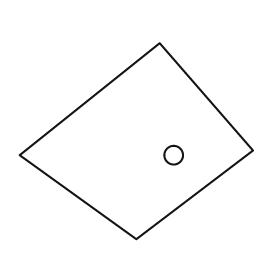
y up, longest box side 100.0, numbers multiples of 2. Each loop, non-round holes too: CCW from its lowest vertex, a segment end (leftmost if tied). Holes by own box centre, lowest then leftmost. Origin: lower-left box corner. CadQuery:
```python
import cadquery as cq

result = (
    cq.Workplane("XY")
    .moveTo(50.0, 0.0)
    .lineTo(100.0, 38.0)
    .lineTo(60.0, 84.0)
    .lineTo(0.0, 36.0)
    .close()
    .moveTo(66.0, 36.0)
    .circle(4.0)
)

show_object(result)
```